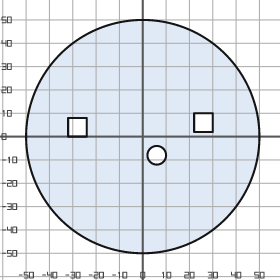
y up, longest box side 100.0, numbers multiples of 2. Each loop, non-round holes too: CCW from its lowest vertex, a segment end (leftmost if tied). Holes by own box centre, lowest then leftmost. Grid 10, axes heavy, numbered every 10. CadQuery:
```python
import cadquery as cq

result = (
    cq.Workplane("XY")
    .moveTo(0.0, 0.0)
    .circle(50.0)
    .moveTo(6.0, -8.0)
    .circle(4.0)
    .moveTo(-32.0, 0.0)
    .lineTo(-24.0, 0.0)
    .lineTo(-24.0, 8.0)
    .lineTo(-32.0, 8.0)
    .close()
    .moveTo(22.0, 2.0)
    .lineTo(30.0, 2.0)
    .lineTo(30.0, 10.0)
    .lineTo(22.0, 10.0)
    .close()
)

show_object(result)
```